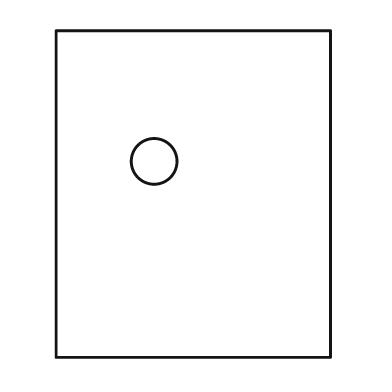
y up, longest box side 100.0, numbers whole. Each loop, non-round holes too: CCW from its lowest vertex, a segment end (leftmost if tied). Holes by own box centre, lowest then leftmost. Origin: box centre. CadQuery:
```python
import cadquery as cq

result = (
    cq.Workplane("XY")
    .moveTo(-42.0, -50.0)
    .lineTo(42.0, -50.0)
    .lineTo(42.0, 50.0)
    .lineTo(-42.0, 50.0)
    .close()
    .moveTo(-12.0, 10.0)
    .circle(7.0)
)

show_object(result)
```